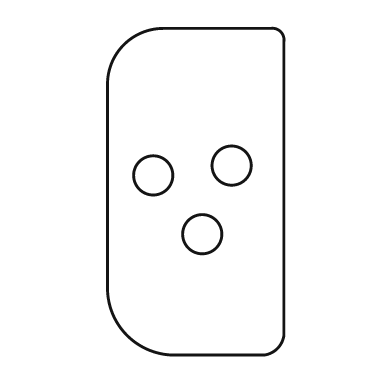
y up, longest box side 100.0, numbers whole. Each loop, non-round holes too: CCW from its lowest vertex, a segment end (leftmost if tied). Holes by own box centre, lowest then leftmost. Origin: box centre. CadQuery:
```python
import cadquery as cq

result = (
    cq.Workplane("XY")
    .moveTo(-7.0, -50.0)
    .lineTo(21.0, -50.0)
    .threePointArc((25.0, -48.0), (27.0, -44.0))
    .lineTo(27.0, 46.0)
    .threePointArc((26.0, 49.0), (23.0, 50.0))
    .lineTo(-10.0, 50.0)
    .threePointArc((-22.0, 45.0), (-27.0, 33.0))
    .lineTo(-27.0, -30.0)
    .threePointArc((-21.0, -44.0), (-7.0, -50.0))
    .close()
    .moveTo(2.0, -13.0)
    .circle(6.0)
    .moveTo(-13.0, 5.0)
    .circle(6.0)
    .moveTo(11.0, 8.0)
    .circle(6.0)
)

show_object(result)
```